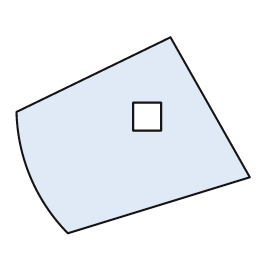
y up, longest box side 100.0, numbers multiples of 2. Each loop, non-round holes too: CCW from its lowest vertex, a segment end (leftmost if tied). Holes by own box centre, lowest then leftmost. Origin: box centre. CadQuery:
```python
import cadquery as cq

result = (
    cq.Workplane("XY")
    .moveTo(-28.0, -42.0)
    .lineTo(50.0, -18.0)
    .lineTo(16.0, 42.0)
    .lineTo(-50.0, 10.0)
    .threePointArc((-44.0, -18.0), (-28.0, -42.0))
    .close()
    .moveTo(0.0, 2.0)
    .lineTo(12.0, 2.0)
    .lineTo(12.0, 14.0)
    .lineTo(0.0, 14.0)
    .close()
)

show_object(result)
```